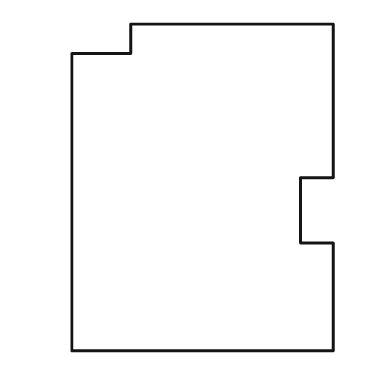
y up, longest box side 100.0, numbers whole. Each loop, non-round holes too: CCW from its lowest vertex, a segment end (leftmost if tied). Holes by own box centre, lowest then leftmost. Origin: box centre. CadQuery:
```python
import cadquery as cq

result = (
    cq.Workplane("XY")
    .moveTo(-40.0, -50.0)
    .lineTo(40.0, -50.0)
    .lineTo(40.0, -17.0)
    .lineTo(30.0, -17.0)
    .lineTo(30.0, 3.0)
    .lineTo(40.0, 3.0)
    .lineTo(40.0, 50.0)
    .lineTo(-22.0, 50.0)
    .lineTo(-22.0, 41.0)
    .lineTo(-40.0, 41.0)
    .close()
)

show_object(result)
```